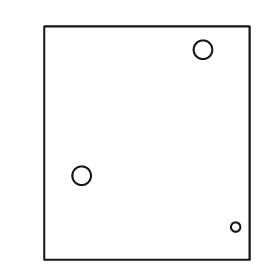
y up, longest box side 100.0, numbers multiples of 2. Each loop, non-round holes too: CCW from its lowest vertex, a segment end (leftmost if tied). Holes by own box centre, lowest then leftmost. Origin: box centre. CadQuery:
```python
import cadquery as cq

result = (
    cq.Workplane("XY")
    .moveTo(-44.0, -50.0)
    .lineTo(44.0, -50.0)
    .lineTo(44.0, 50.0)
    .lineTo(-44.0, 50.0)
    .close()
    .moveTo(38.0, -36.0)
    .circle(2.0)
    .moveTo(-28.0, -14.0)
    .circle(4.0)
    .moveTo(24.0, 40.0)
    .circle(4.0)
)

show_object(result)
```